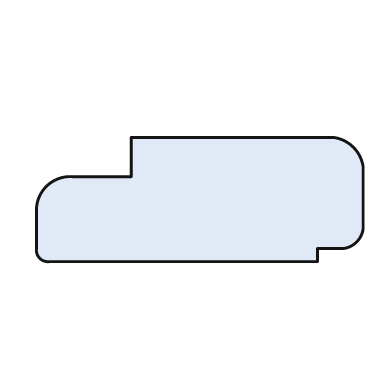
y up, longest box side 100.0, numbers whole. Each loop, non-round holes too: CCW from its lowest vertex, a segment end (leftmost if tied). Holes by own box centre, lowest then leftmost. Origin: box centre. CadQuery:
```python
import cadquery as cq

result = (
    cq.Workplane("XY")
    .moveTo(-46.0, -19.0)
    .lineTo(36.0, -19.0)
    .lineTo(36.0, -15.0)
    .lineTo(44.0, -15.0)
    .threePointArc((48.0, -13.0), (50.0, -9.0))
    .lineTo(50.0, 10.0)
    .threePointArc((47.0, 16.0), (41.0, 19.0))
    .lineTo(-21.0, 19.0)
    .lineTo(-21.0, 7.0)
    .lineTo(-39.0, 7.0)
    .threePointArc((-47.0, 4.0), (-50.0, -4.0))
    .lineTo(-50.0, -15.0)
    .threePointArc((-49.0, -18.0), (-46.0, -19.0))
    .close()
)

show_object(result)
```